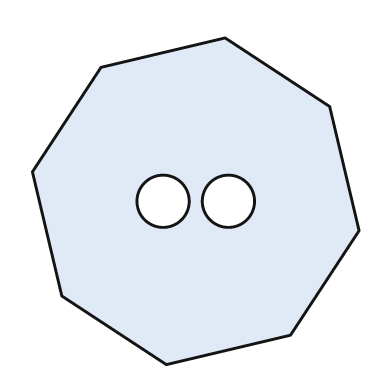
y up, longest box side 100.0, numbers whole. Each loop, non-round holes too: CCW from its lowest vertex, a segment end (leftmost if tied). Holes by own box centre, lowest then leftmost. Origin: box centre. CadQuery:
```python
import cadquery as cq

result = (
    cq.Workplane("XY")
    .moveTo(-9.0, -50.0)
    .lineTo(29.0, -41.0)
    .lineTo(50.0, -9.0)
    .lineTo(41.0, 29.0)
    .lineTo(9.0, 50.0)
    .lineTo(-29.0, 41.0)
    .lineTo(-50.0, 9.0)
    .lineTo(-41.0, -29.0)
    .close()
    .moveTo(-10.0, 0.0)
    .circle(8.0)
    .moveTo(10.0, 0.0)
    .circle(8.0)
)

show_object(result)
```